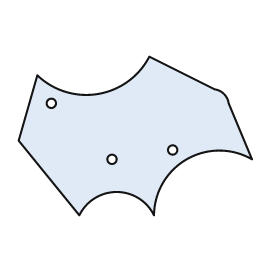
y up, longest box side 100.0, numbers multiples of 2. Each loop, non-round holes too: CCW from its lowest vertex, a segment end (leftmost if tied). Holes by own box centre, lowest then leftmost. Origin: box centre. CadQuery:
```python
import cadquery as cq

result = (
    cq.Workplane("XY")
    .moveTo(-24.0, -34.0)
    .threePointArc((-8.0, -24.0), (8.0, -34.0))
    .threePointArc((22.0, -10.0), (50.0, -10.0))
    .lineTo(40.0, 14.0)
    .threePointArc((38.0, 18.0), (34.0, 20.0))
    .lineTo(6.0, 34.0)
    .threePointArc((-16.0, 18.0), (-42.0, 26.0))
    .lineTo(-50.0, -2.0)
    .close()
    .moveTo(-10.0, -10.0)
    .circle(2.0)
    .moveTo(16.0, -6.0)
    .circle(2.0)
    .moveTo(-36.0, 14.0)
    .circle(2.0)
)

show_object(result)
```